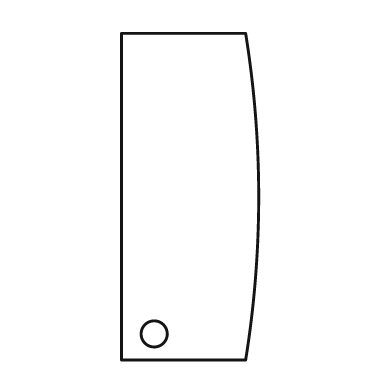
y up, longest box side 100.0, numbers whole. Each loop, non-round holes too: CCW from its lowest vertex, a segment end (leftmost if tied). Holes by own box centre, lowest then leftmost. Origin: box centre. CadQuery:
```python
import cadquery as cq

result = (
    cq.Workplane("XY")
    .moveTo(-21.0, -50.0)
    .lineTo(17.0, -50.0)
    .threePointArc((21.0, 0.0), (17.0, 50.0))
    .lineTo(-21.0, 50.0)
    .close()
    .moveTo(-11.0, -42.0)
    .circle(4.0)
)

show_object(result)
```